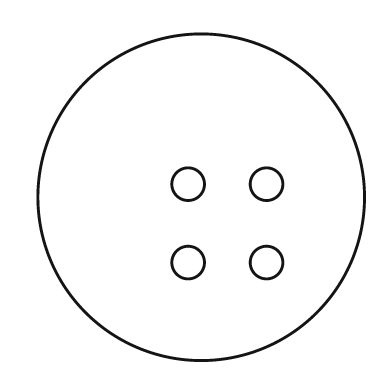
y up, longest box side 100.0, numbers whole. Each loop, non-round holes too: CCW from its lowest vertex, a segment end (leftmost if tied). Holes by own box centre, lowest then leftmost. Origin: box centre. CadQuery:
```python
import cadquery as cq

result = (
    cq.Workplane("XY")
    .moveTo(0.0, 0.0)
    .circle(50.0)
    .moveTo(-4.0, -20.0)
    .circle(5.0)
    .moveTo(20.0, -20.0)
    .circle(5.0)
    .moveTo(-4.0, 4.0)
    .circle(5.0)
    .moveTo(20.0, 4.0)
    .circle(5.0)
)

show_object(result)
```